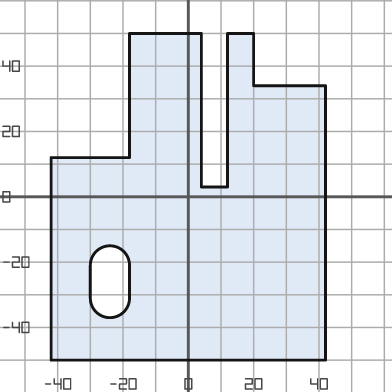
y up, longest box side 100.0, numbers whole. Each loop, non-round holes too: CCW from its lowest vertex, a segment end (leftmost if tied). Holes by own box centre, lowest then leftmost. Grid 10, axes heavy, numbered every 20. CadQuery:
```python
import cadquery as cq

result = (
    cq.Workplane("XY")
    .moveTo(-42.0, -50.0)
    .lineTo(42.0, -50.0)
    .lineTo(42.0, 34.0)
    .lineTo(20.0, 34.0)
    .lineTo(20.0, 50.0)
    .lineTo(12.0, 50.0)
    .lineTo(12.0, 3.0)
    .lineTo(4.0, 3.0)
    .lineTo(4.0, 50.0)
    .lineTo(-18.0, 50.0)
    .lineTo(-18.0, 12.0)
    .lineTo(-42.0, 12.0)
    .close()
    .moveTo(-30.0, -31.0)
    .threePointArc((-24.0, -37.0), (-18.0, -31.0))
    .lineTo(-18.0, -21.0)
    .threePointArc((-24.0, -15.0), (-30.0, -21.0))
    .close()
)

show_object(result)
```